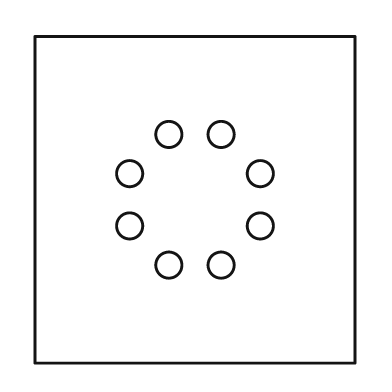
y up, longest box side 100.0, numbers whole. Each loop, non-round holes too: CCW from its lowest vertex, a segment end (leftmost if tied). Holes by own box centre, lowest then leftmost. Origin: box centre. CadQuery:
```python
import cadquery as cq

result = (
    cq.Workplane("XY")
    .moveTo(-49.0, -50.0)
    .lineTo(49.0, -50.0)
    .lineTo(49.0, 50.0)
    .lineTo(-49.0, 50.0)
    .close()
    .moveTo(-8.0, -20.0)
    .circle(4.0)
    .moveTo(8.0, -20.0)
    .circle(4.0)
    .moveTo(-20.0, -8.0)
    .circle(4.0)
    .moveTo(20.0, -8.0)
    .circle(4.0)
    .moveTo(-20.0, 8.0)
    .circle(4.0)
    .moveTo(20.0, 8.0)
    .circle(4.0)
    .moveTo(-8.0, 20.0)
    .circle(4.0)
    .moveTo(8.0, 20.0)
    .circle(4.0)
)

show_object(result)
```